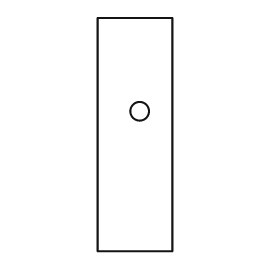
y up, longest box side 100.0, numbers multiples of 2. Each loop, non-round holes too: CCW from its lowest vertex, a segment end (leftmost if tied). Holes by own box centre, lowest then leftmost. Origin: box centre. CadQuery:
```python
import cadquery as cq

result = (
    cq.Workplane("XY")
    .moveTo(-16.0, -50.0)
    .lineTo(16.0, -50.0)
    .lineTo(16.0, 50.0)
    .lineTo(-16.0, 50.0)
    .close()
    .moveTo(2.0, 10.0)
    .circle(4.0)
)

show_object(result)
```